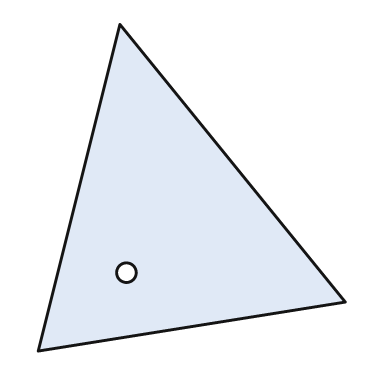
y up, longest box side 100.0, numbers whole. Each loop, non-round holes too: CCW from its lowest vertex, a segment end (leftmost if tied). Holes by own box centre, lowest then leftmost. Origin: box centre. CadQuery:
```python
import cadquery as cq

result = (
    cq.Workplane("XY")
    .moveTo(-47.0, -50.0)
    .lineTo(47.0, -35.0)
    .lineTo(-22.0, 50.0)
    .close()
    .moveTo(-20.0, -26.0)
    .circle(3.0)
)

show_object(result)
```